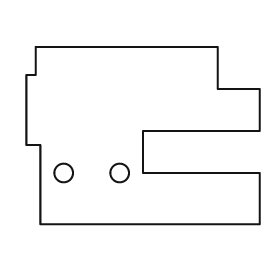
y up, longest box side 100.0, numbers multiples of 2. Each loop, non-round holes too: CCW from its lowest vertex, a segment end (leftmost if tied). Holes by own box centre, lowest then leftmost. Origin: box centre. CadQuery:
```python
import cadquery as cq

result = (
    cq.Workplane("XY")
    .moveTo(-44.0, -38.0)
    .lineTo(50.0, -38.0)
    .lineTo(50.0, -16.0)
    .lineTo(0.0, -16.0)
    .lineTo(0.0, 2.0)
    .lineTo(50.0, 2.0)
    .lineTo(50.0, 20.0)
    .lineTo(32.0, 20.0)
    .lineTo(32.0, 38.0)
    .lineTo(-46.0, 38.0)
    .lineTo(-46.0, 26.0)
    .lineTo(-50.0, 26.0)
    .lineTo(-50.0, -4.0)
    .lineTo(-44.0, -4.0)
    .close()
    .moveTo(-34.0, -16.0)
    .circle(4.0)
    .moveTo(-10.0, -16.0)
    .circle(4.0)
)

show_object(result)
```